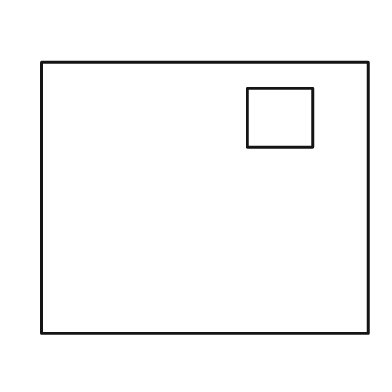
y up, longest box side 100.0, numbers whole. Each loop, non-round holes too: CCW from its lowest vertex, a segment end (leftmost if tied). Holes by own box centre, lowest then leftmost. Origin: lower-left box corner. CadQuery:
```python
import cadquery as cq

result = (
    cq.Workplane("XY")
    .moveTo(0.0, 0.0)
    .lineTo(100.0, 0.0)
    .lineTo(100.0, 83.0)
    .lineTo(0.0, 83.0)
    .close()
    .moveTo(63.0, 57.0)
    .lineTo(83.0, 57.0)
    .lineTo(83.0, 75.0)
    .lineTo(63.0, 75.0)
    .close()
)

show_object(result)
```